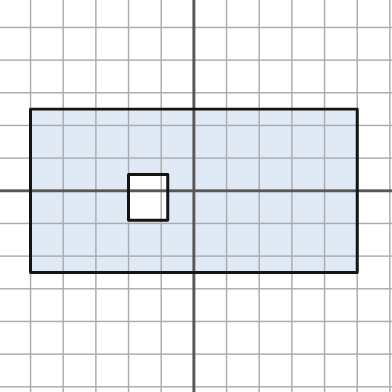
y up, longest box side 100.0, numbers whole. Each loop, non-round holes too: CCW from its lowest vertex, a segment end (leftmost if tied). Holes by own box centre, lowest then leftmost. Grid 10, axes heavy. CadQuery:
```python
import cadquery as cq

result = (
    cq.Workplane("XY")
    .moveTo(-50.0, -25.0)
    .lineTo(50.0, -25.0)
    .lineTo(50.0, 25.0)
    .lineTo(-50.0, 25.0)
    .close()
    .moveTo(-20.0, -9.0)
    .lineTo(-8.0, -9.0)
    .lineTo(-8.0, 5.0)
    .lineTo(-20.0, 5.0)
    .close()
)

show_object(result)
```